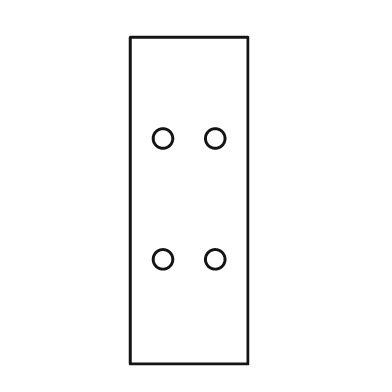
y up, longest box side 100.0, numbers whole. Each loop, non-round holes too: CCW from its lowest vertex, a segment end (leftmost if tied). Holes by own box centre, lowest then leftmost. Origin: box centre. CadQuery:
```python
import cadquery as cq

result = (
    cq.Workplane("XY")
    .moveTo(-18.0, -50.0)
    .lineTo(18.0, -50.0)
    .lineTo(18.0, 50.0)
    .lineTo(-18.0, 50.0)
    .close()
    .moveTo(-8.0, -18.0)
    .circle(3.0)
    .moveTo(8.0, -18.0)
    .circle(3.0)
    .moveTo(-8.0, 19.0)
    .circle(3.0)
    .moveTo(8.0, 19.0)
    .circle(3.0)
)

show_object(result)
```